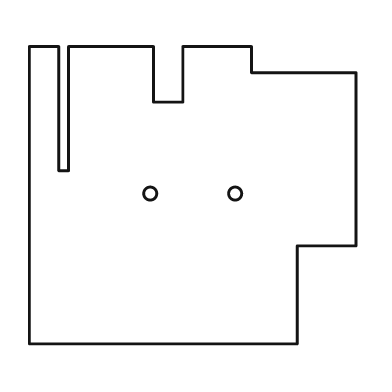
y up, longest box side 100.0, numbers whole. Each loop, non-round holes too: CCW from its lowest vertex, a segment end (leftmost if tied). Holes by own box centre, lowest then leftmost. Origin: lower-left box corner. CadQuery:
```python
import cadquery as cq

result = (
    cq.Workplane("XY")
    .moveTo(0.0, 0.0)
    .lineTo(82.0, 0.0)
    .lineTo(82.0, 30.0)
    .lineTo(100.0, 30.0)
    .lineTo(100.0, 83.0)
    .lineTo(68.0, 83.0)
    .lineTo(68.0, 91.0)
    .lineTo(47.0, 91.0)
    .lineTo(47.0, 74.0)
    .lineTo(38.0, 74.0)
    .lineTo(38.0, 91.0)
    .lineTo(12.0, 91.0)
    .lineTo(12.0, 53.0)
    .lineTo(9.0, 53.0)
    .lineTo(9.0, 91.0)
    .lineTo(0.0, 91.0)
    .close()
    .moveTo(37.0, 46.0)
    .circle(2.0)
    .moveTo(63.0, 46.0)
    .circle(2.0)
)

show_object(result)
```